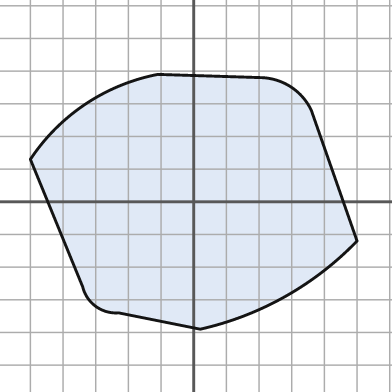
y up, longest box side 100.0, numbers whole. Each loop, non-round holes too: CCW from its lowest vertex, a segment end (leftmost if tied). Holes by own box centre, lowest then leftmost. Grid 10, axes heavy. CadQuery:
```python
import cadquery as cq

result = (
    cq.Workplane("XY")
    .moveTo(2.0, -39.0)
    .threePointArc((28.0, -29.0), (50.0, -12.0))
    .lineTo(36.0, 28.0)
    .threePointArc((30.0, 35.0), (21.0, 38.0))
    .lineTo(-11.0, 39.0)
    .threePointArc((-33.0, 30.0), (-50.0, 13.0))
    .lineTo(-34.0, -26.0)
    .threePointArc((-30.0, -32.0), (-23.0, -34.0))
    .close()
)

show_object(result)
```